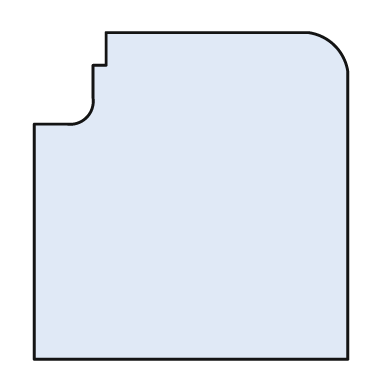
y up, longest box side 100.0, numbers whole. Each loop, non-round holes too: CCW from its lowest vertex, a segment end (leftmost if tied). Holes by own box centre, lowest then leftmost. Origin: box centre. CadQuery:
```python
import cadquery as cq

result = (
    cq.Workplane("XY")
    .moveTo(-48.0, -50.0)
    .lineTo(48.0, -50.0)
    .lineTo(48.0, 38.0)
    .threePointArc((44.0, 46.0), (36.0, 50.0))
    .lineTo(-26.0, 50.0)
    .lineTo(-26.0, 40.0)
    .lineTo(-30.0, 40.0)
    .lineTo(-30.0, 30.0)
    .threePointArc((-32.0, 24.0), (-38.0, 22.0))
    .lineTo(-48.0, 22.0)
    .close()
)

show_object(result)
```